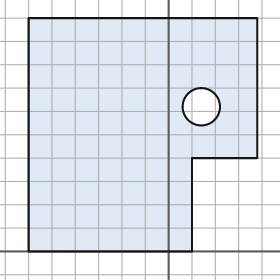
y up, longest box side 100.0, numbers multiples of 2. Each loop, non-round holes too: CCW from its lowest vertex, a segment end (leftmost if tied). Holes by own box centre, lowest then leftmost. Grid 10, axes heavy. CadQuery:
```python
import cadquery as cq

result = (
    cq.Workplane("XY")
    .moveTo(-60.0, 0.0)
    .lineTo(10.0, 0.0)
    .lineTo(10.0, 40.0)
    .lineTo(38.0, 40.0)
    .lineTo(38.0, 100.0)
    .lineTo(-60.0, 100.0)
    .close()
    .moveTo(14.0, 62.0)
    .circle(8.0)
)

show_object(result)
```